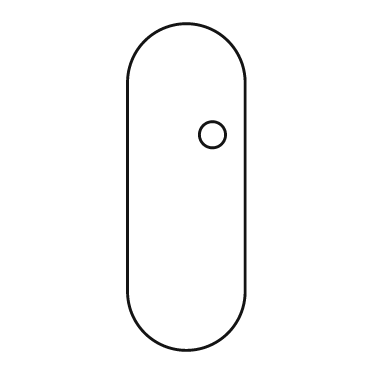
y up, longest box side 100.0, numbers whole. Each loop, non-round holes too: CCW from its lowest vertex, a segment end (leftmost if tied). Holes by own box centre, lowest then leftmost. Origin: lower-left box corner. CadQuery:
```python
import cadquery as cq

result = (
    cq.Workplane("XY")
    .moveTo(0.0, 18.0)
    .threePointArc((18.0, 0.0), (36.0, 18.0))
    .lineTo(36.0, 82.0)
    .threePointArc((18.0, 100.0), (0.0, 82.0))
    .close()
    .moveTo(26.0, 66.0)
    .circle(4.0)
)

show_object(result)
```